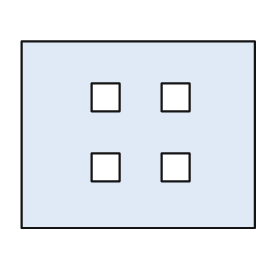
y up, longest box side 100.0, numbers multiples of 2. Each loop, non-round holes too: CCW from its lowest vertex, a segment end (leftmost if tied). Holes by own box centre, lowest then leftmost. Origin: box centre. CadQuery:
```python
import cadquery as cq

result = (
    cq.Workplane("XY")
    .moveTo(-50.0, -40.0)
    .lineTo(50.0, -40.0)
    .lineTo(50.0, 40.0)
    .lineTo(-50.0, 40.0)
    .close()
    .moveTo(-20.0, -20.0)
    .lineTo(-8.0, -20.0)
    .lineTo(-8.0, -8.0)
    .lineTo(-20.0, -8.0)
    .close()
    .moveTo(10.0, -20.0)
    .lineTo(22.0, -20.0)
    .lineTo(22.0, -8.0)
    .lineTo(10.0, -8.0)
    .close()
    .moveTo(-20.0, 10.0)
    .lineTo(-8.0, 10.0)
    .lineTo(-8.0, 22.0)
    .lineTo(-20.0, 22.0)
    .close()
    .moveTo(10.0, 10.0)
    .lineTo(22.0, 10.0)
    .lineTo(22.0, 22.0)
    .lineTo(10.0, 22.0)
    .close()
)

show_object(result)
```